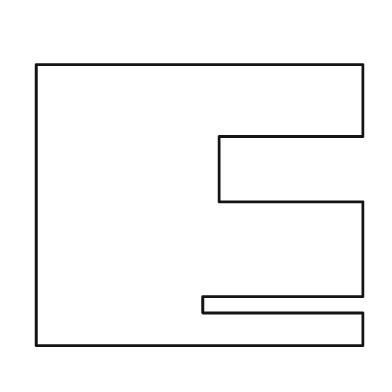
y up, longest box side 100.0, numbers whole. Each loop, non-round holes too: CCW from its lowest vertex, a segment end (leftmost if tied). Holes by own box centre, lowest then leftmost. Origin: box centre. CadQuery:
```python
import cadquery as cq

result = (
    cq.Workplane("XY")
    .moveTo(-50.0, -43.0)
    .lineTo(50.0, -43.0)
    .lineTo(50.0, -33.0)
    .lineTo(1.0, -33.0)
    .lineTo(1.0, -28.0)
    .lineTo(50.0, -28.0)
    .lineTo(50.0, 1.0)
    .lineTo(6.0, 1.0)
    .lineTo(6.0, 21.0)
    .lineTo(50.0, 21.0)
    .lineTo(50.0, 43.0)
    .lineTo(-50.0, 43.0)
    .close()
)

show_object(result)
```